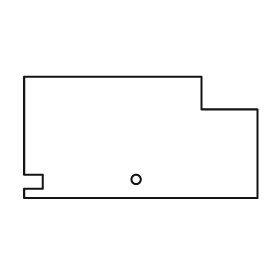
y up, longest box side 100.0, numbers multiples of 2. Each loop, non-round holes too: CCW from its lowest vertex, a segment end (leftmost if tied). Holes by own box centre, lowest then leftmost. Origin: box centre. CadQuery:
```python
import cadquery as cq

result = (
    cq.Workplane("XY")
    .moveTo(-50.0, -26.0)
    .lineTo(50.0, -26.0)
    .lineTo(50.0, 12.0)
    .lineTo(26.0, 12.0)
    .lineTo(26.0, 26.0)
    .lineTo(-50.0, 26.0)
    .lineTo(-50.0, -16.0)
    .lineTo(-42.0, -16.0)
    .lineTo(-42.0, -22.0)
    .lineTo(-50.0, -22.0)
    .close()
    .moveTo(-2.0, -18.0)
    .circle(2.0)
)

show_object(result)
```